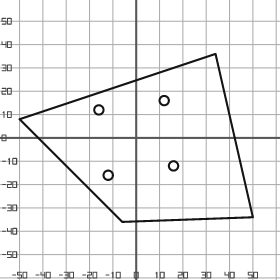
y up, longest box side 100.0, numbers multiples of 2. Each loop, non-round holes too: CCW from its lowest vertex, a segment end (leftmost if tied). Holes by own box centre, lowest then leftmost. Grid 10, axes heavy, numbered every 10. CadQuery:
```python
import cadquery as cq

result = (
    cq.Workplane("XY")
    .moveTo(-6.0, -36.0)
    .lineTo(50.0, -34.0)
    .lineTo(34.0, 36.0)
    .lineTo(-50.0, 8.0)
    .close()
    .moveTo(-12.0, -16.0)
    .circle(2.0)
    .moveTo(16.0, -12.0)
    .circle(2.0)
    .moveTo(-16.0, 12.0)
    .circle(2.0)
    .moveTo(12.0, 16.0)
    .circle(2.0)
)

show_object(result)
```